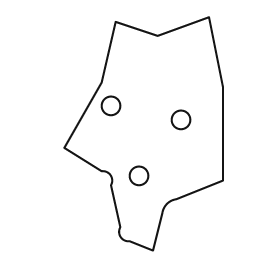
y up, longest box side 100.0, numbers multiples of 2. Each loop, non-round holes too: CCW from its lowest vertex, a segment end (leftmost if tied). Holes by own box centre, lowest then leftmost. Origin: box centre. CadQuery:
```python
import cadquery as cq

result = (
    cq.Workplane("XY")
    .moveTo(4.0, -50.0)
    .lineTo(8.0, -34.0)
    .threePointArc((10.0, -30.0), (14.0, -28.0))
    .lineTo(34.0, -20.0)
    .lineTo(34.0, 20.0)
    .lineTo(28.0, 50.0)
    .lineTo(6.0, 42.0)
    .lineTo(-12.0, 48.0)
    .lineTo(-18.0, 22.0)
    .lineTo(-34.0, -6.0)
    .lineTo(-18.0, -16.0)
    .threePointArc((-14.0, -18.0), (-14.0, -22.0))
    .lineTo(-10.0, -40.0)
    .threePointArc((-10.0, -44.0), (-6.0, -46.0))
    .close()
    .moveTo(-2.0, -18.0)
    .circle(4.0)
    .moveTo(16.0, 6.0)
    .circle(4.0)
    .moveTo(-14.0, 12.0)
    .circle(4.0)
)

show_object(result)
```